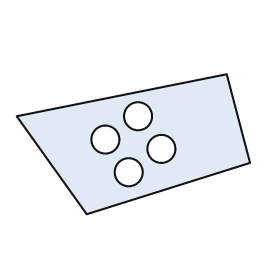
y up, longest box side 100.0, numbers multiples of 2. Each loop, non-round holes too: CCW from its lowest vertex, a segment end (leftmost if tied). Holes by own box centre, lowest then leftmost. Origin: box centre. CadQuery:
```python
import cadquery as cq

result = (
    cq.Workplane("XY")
    .moveTo(-20.0, -30.0)
    .lineTo(50.0, -8.0)
    .lineTo(40.0, 30.0)
    .lineTo(-50.0, 12.0)
    .close()
    .moveTo(-2.0, -12.0)
    .circle(6.0)
    .moveTo(12.0, -2.0)
    .circle(6.0)
    .moveTo(-12.0, 2.0)
    .circle(6.0)
    .moveTo(2.0, 12.0)
    .circle(6.0)
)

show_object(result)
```